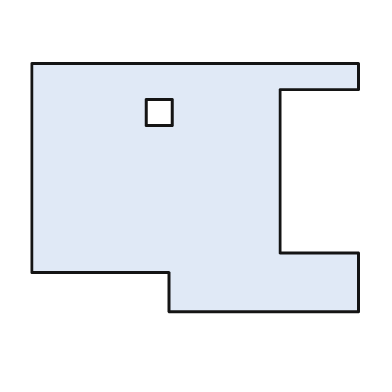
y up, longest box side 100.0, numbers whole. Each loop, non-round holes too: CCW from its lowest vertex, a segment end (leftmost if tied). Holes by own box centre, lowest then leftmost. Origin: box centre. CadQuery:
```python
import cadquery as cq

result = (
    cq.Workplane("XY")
    .moveTo(-8.0, -38.0)
    .lineTo(50.0, -38.0)
    .lineTo(50.0, -20.0)
    .lineTo(26.0, -20.0)
    .lineTo(26.0, 30.0)
    .lineTo(50.0, 30.0)
    .lineTo(50.0, 38.0)
    .lineTo(-50.0, 38.0)
    .lineTo(-50.0, -26.0)
    .lineTo(-8.0, -26.0)
    .close()
    .moveTo(-15.0, 19.0)
    .lineTo(-7.0, 19.0)
    .lineTo(-7.0, 27.0)
    .lineTo(-15.0, 27.0)
    .close()
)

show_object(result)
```